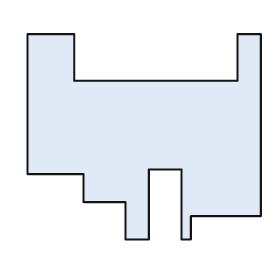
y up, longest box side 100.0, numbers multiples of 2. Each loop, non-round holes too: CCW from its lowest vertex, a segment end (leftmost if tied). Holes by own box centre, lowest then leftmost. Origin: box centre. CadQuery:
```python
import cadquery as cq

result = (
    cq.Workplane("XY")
    .moveTo(-8.0, -44.0)
    .lineTo(2.0, -44.0)
    .lineTo(2.0, -14.0)
    .lineTo(16.0, -14.0)
    .lineTo(16.0, -44.0)
    .lineTo(20.0, -44.0)
    .lineTo(20.0, -34.0)
    .lineTo(50.0, -34.0)
    .lineTo(50.0, 44.0)
    .lineTo(40.0, 44.0)
    .lineTo(40.0, 24.0)
    .lineTo(-30.0, 24.0)
    .lineTo(-30.0, 44.0)
    .lineTo(-50.0, 44.0)
    .lineTo(-50.0, -16.0)
    .lineTo(-26.0, -16.0)
    .lineTo(-26.0, -28.0)
    .lineTo(-8.0, -28.0)
    .close()
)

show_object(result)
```